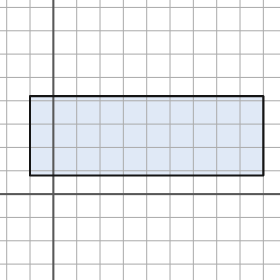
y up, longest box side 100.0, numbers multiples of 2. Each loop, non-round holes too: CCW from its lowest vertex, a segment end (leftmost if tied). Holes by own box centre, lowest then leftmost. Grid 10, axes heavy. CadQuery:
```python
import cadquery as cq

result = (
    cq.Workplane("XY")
    .moveTo(-10.0, 8.0)
    .lineTo(90.0, 8.0)
    .lineTo(90.0, 42.0)
    .lineTo(-10.0, 42.0)
    .close()
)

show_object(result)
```